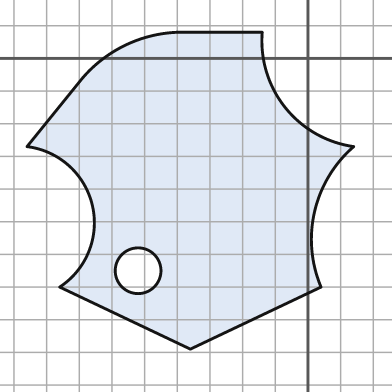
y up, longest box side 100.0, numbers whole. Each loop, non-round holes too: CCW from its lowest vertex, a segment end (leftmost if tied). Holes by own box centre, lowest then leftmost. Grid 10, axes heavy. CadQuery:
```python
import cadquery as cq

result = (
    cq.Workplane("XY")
    .moveTo(-36.0, -89.0)
    .lineTo(4.0, -70.0)
    .threePointArc((2.0, -47.0), (14.0, -27.0))
    .threePointArc((-7.0, -15.0), (-14.0, 8.0))
    .lineTo(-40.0, 8.0)
    .threePointArc((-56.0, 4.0), (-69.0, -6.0))
    .lineTo(-86.0, -27.0)
    .threePointArc((-66.0, -45.0), (-76.0, -70.0))
    .close()
    .moveTo(-52.0, -65.0)
    .circle(7.0)
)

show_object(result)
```